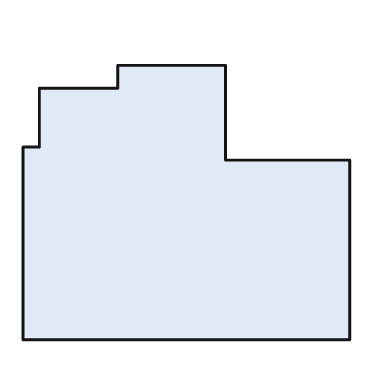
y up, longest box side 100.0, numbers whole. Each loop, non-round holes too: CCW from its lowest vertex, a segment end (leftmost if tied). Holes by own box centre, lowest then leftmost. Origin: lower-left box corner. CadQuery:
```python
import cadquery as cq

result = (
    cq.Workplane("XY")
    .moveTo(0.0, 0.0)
    .lineTo(100.0, 0.0)
    .lineTo(100.0, 55.0)
    .lineTo(62.0, 55.0)
    .lineTo(62.0, 84.0)
    .lineTo(29.0, 84.0)
    .lineTo(29.0, 77.0)
    .lineTo(5.0, 77.0)
    .lineTo(5.0, 59.0)
    .lineTo(0.0, 59.0)
    .close()
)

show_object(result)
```